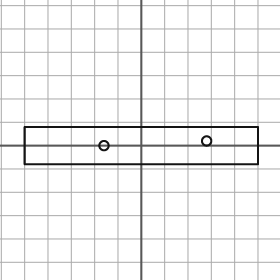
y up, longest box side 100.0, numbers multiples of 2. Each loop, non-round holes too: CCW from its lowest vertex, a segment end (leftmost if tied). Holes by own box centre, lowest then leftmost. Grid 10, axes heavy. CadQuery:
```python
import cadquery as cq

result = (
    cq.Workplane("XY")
    .moveTo(-50.0, -8.0)
    .lineTo(50.0, -8.0)
    .lineTo(50.0, 8.0)
    .lineTo(-50.0, 8.0)
    .close()
    .moveTo(-16.0, 0.0)
    .circle(2.0)
    .moveTo(28.0, 2.0)
    .circle(2.0)
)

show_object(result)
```